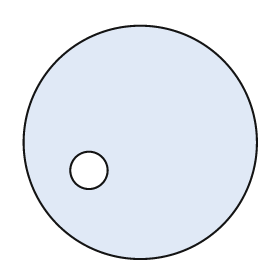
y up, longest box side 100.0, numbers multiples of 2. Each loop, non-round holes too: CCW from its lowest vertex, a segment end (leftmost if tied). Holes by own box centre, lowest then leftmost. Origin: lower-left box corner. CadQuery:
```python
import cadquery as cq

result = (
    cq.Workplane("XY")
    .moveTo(50.0, 50.0)
    .circle(50.0)
    .moveTo(28.0, 38.0)
    .circle(8.0)
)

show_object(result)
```